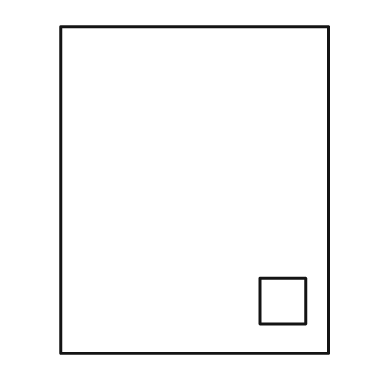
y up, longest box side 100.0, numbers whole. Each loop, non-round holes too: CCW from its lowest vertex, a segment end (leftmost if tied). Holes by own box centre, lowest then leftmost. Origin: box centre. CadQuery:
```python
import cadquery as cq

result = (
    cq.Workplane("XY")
    .moveTo(-41.0, -50.0)
    .lineTo(41.0, -50.0)
    .lineTo(41.0, 50.0)
    .lineTo(-41.0, 50.0)
    .close()
    .moveTo(20.0, -41.0)
    .lineTo(34.0, -41.0)
    .lineTo(34.0, -27.0)
    .lineTo(20.0, -27.0)
    .close()
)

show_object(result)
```